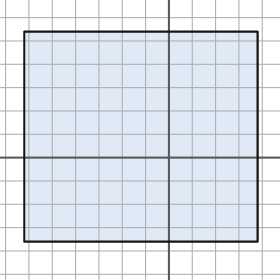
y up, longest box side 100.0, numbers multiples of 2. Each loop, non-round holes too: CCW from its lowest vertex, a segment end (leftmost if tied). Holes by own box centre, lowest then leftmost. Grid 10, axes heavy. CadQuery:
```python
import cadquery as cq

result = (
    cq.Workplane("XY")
    .moveTo(-62.0, -36.0)
    .lineTo(38.0, -36.0)
    .lineTo(38.0, 54.0)
    .lineTo(-62.0, 54.0)
    .close()
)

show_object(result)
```